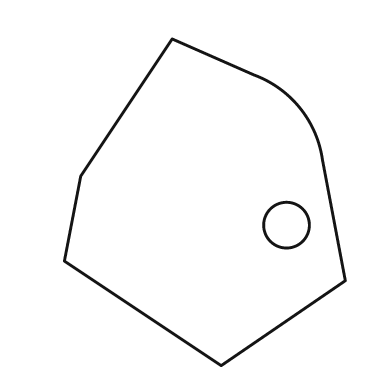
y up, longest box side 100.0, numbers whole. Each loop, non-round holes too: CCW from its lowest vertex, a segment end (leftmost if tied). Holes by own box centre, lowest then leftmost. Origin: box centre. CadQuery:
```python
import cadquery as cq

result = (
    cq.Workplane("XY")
    .moveTo(5.0, -50.0)
    .lineTo(43.0, -24.0)
    .lineTo(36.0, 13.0)
    .threePointArc((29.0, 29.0), (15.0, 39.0))
    .lineTo(-10.0, 50.0)
    .lineTo(-38.0, 8.0)
    .lineTo(-43.0, -18.0)
    .close()
    .moveTo(25.0, -7.0)
    .circle(7.0)
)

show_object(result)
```